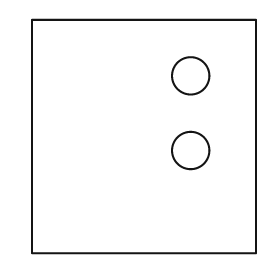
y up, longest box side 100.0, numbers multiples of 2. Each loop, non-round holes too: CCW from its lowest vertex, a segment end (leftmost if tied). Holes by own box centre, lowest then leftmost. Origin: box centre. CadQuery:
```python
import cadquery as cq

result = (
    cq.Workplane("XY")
    .moveTo(-48.0, -50.0)
    .lineTo(48.0, -50.0)
    .lineTo(48.0, 50.0)
    .lineTo(-48.0, 50.0)
    .close()
    .moveTo(20.0, -6.0)
    .circle(8.0)
    .moveTo(20.0, 26.0)
    .circle(8.0)
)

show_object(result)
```